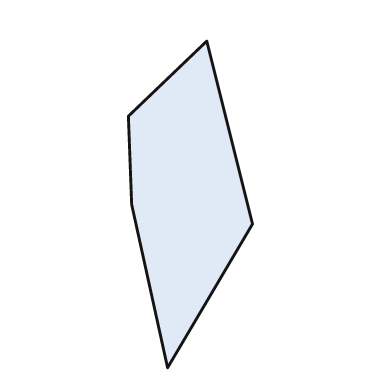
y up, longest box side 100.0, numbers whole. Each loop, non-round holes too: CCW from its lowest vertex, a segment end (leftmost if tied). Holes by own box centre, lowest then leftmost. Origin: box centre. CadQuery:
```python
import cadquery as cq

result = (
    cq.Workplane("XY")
    .moveTo(-7.0, -50.0)
    .lineTo(19.0, -6.0)
    .lineTo(5.0, 50.0)
    .lineTo(-19.0, 27.0)
    .lineTo(-18.0, 0.0)
    .close()
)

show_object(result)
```